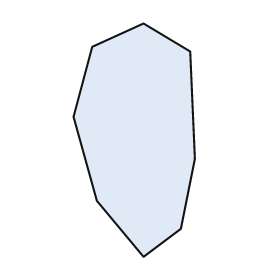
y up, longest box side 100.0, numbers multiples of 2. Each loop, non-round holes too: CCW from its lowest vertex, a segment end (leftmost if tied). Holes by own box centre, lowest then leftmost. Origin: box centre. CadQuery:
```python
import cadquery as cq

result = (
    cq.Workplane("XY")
    .moveTo(4.0, -50.0)
    .lineTo(20.0, -38.0)
    .lineTo(26.0, -8.0)
    .lineTo(24.0, 38.0)
    .lineTo(4.0, 50.0)
    .lineTo(-18.0, 40.0)
    .lineTo(-26.0, 10.0)
    .lineTo(-16.0, -26.0)
    .close()
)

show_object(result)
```